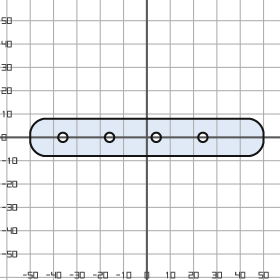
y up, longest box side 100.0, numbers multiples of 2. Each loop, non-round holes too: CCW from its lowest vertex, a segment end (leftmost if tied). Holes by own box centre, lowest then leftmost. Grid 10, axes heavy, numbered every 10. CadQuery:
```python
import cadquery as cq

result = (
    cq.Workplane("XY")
    .moveTo(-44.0, -8.0)
    .lineTo(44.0, -8.0)
    .threePointArc((48.0, -6.0), (50.0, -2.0))
    .lineTo(50.0, 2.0)
    .threePointArc((48.0, 6.0), (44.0, 8.0))
    .lineTo(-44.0, 8.0)
    .threePointArc((-48.0, 6.0), (-50.0, 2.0))
    .lineTo(-50.0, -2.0)
    .threePointArc((-48.0, -6.0), (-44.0, -8.0))
    .close()
    .moveTo(-36.0, 0.0)
    .circle(2.0)
    .moveTo(-16.0, 0.0)
    .circle(2.0)
    .moveTo(4.0, 0.0)
    .circle(2.0)
    .moveTo(24.0, 0.0)
    .circle(2.0)
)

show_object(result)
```